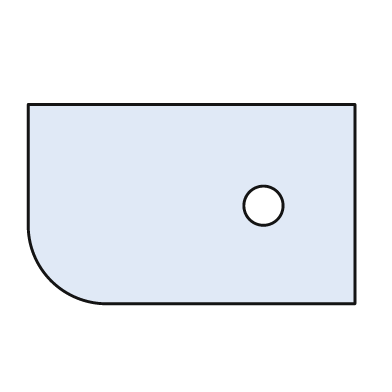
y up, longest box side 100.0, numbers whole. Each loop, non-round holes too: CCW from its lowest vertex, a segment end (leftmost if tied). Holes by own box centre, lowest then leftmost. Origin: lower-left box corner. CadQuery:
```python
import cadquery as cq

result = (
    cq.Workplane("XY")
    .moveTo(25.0, 0.0)
    .lineTo(100.0, 0.0)
    .lineTo(100.0, 61.0)
    .lineTo(0.0, 61.0)
    .lineTo(0.0, 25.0)
    .threePointArc((7.0, 7.0), (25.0, 0.0))
    .close()
    .moveTo(72.0, 30.0)
    .circle(6.0)
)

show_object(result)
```